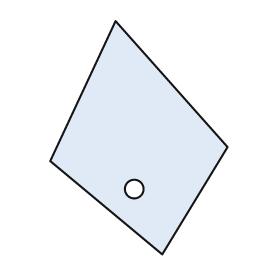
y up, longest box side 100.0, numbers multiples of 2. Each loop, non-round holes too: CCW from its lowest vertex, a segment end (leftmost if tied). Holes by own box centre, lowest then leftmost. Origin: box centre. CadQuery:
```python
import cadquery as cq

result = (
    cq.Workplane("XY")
    .moveTo(10.0, -50.0)
    .lineTo(38.0, -4.0)
    .lineTo(-10.0, 50.0)
    .lineTo(-38.0, -10.0)
    .close()
    .moveTo(-2.0, -22.0)
    .circle(4.0)
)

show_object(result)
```